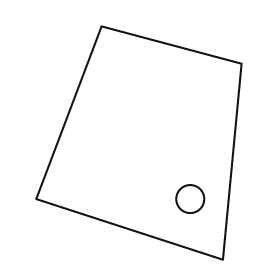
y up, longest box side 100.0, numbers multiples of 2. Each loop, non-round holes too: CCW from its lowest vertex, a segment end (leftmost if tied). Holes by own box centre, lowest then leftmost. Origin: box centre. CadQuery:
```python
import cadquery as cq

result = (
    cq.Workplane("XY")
    .moveTo(36.0, -50.0)
    .lineTo(44.0, 34.0)
    .lineTo(-16.0, 50.0)
    .lineTo(-44.0, -24.0)
    .close()
    .moveTo(22.0, -24.0)
    .circle(6.0)
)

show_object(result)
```